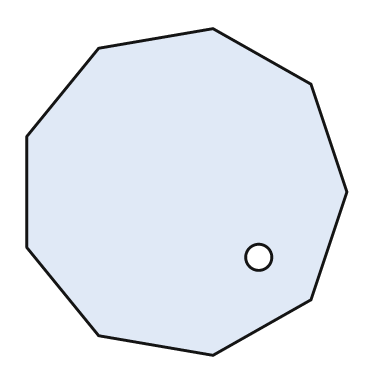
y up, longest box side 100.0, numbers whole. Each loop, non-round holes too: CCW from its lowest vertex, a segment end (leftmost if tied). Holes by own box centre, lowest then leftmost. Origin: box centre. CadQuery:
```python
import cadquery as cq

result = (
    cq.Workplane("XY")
    .moveTo(8.0, -50.0)
    .lineTo(38.0, -33.0)
    .lineTo(49.0, 0.0)
    .lineTo(38.0, 33.0)
    .lineTo(8.0, 50.0)
    .lineTo(-27.0, 44.0)
    .lineTo(-49.0, 17.0)
    .lineTo(-49.0, -17.0)
    .lineTo(-27.0, -44.0)
    .close()
    .moveTo(22.0, -20.0)
    .circle(4.0)
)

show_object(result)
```